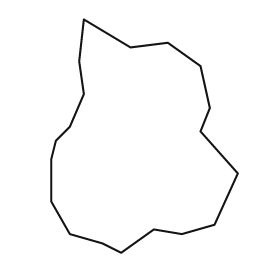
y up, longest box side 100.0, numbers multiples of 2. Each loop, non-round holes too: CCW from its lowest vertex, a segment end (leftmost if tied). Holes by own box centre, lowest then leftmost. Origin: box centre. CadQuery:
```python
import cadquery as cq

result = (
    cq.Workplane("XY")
    .moveTo(-10.0, -50.0)
    .lineTo(4.0, -40.0)
    .lineTo(16.0, -42.0)
    .lineTo(30.0, -38.0)
    .lineTo(40.0, -16.0)
    .lineTo(24.0, 2.0)
    .lineTo(28.0, 12.0)
    .lineTo(24.0, 30.0)
    .lineTo(10.0, 40.0)
    .lineTo(-6.0, 38.0)
    .lineTo(-26.0, 50.0)
    .lineTo(-28.0, 32.0)
    .lineTo(-26.0, 18.0)
    .lineTo(-32.0, 4.0)
    .lineTo(-38.0, -2.0)
    .lineTo(-40.0, -10.0)
    .lineTo(-40.0, -28.0)
    .lineTo(-32.0, -42.0)
    .lineTo(-18.0, -46.0)
    .close()
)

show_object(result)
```